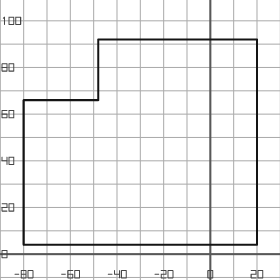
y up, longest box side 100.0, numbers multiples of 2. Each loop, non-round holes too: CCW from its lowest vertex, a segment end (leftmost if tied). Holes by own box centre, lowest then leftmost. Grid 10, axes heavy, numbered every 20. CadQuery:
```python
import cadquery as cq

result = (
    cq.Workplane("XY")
    .moveTo(-80.0, 4.0)
    .lineTo(20.0, 4.0)
    .lineTo(20.0, 92.0)
    .lineTo(-48.0, 92.0)
    .lineTo(-48.0, 66.0)
    .lineTo(-80.0, 66.0)
    .close()
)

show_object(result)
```